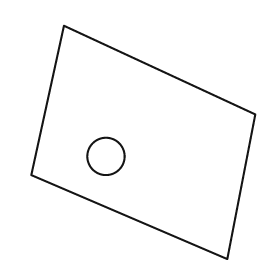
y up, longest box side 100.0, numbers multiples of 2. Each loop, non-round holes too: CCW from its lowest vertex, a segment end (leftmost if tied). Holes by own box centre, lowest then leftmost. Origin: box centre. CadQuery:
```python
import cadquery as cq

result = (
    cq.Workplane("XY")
    .moveTo(36.0, -50.0)
    .lineTo(48.0, 12.0)
    .lineTo(-34.0, 50.0)
    .lineTo(-48.0, -14.0)
    .close()
    .moveTo(-16.0, -6.0)
    .circle(8.0)
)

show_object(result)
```